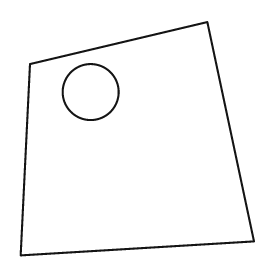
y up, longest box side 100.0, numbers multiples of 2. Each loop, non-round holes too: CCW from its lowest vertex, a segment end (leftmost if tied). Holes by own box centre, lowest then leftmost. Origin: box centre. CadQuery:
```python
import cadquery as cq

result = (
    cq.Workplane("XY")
    .moveTo(-50.0, -50.0)
    .lineTo(50.0, -44.0)
    .lineTo(30.0, 50.0)
    .lineTo(-46.0, 32.0)
    .close()
    .moveTo(-20.0, 20.0)
    .circle(12.0)
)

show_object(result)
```